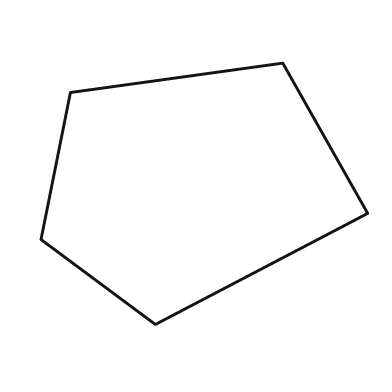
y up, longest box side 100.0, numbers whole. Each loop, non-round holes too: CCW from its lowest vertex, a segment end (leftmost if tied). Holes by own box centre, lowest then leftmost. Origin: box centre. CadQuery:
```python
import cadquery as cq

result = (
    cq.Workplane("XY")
    .moveTo(-15.0, -40.0)
    .lineTo(50.0, -6.0)
    .lineTo(24.0, 40.0)
    .lineTo(-41.0, 31.0)
    .lineTo(-50.0, -14.0)
    .close()
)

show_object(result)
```